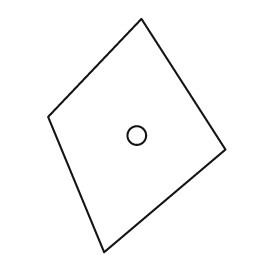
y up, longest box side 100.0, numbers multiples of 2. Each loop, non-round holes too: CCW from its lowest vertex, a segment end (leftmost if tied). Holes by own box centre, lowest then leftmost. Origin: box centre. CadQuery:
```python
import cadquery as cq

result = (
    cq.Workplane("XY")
    .moveTo(-14.0, -50.0)
    .lineTo(38.0, -6.0)
    .lineTo(2.0, 50.0)
    .lineTo(-38.0, 8.0)
    .close()
    .moveTo(0.0, 0.0)
    .circle(4.0)
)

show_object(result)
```